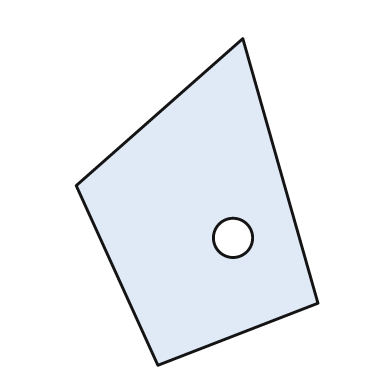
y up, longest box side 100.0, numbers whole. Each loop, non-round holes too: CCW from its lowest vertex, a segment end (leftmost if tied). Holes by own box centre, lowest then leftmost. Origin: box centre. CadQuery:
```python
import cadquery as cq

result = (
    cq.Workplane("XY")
    .moveTo(-12.0, -50.0)
    .lineTo(37.0, -31.0)
    .lineTo(14.0, 50.0)
    .lineTo(-37.0, 5.0)
    .close()
    .moveTo(11.0, -11.0)
    .circle(6.0)
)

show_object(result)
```